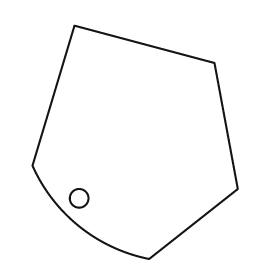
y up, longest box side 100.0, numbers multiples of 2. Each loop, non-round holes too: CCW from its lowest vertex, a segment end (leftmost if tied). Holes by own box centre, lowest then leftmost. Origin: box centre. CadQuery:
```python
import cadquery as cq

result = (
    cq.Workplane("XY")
    .moveTo(6.0, -50.0)
    .lineTo(44.0, -20.0)
    .lineTo(34.0, 34.0)
    .lineTo(-26.0, 50.0)
    .lineTo(-44.0, -10.0)
    .threePointArc((-24.0, -36.0), (6.0, -50.0))
    .close()
    .moveTo(-24.0, -24.0)
    .circle(4.0)
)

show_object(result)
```